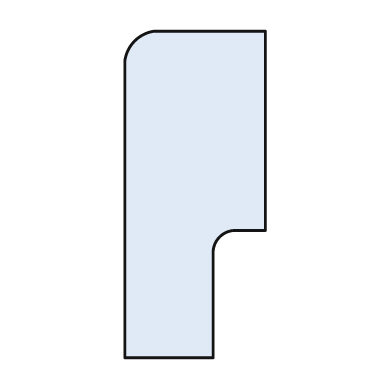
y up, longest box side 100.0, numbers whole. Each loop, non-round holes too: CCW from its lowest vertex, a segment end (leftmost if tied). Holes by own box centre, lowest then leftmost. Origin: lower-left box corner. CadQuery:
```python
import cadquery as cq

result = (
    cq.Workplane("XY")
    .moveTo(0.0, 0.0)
    .lineTo(27.0, 0.0)
    .lineTo(27.0, 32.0)
    .threePointArc((29.0, 37.0), (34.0, 39.0))
    .lineTo(43.0, 39.0)
    .lineTo(43.0, 100.0)
    .lineTo(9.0, 100.0)
    .threePointArc((3.0, 97.0), (0.0, 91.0))
    .close()
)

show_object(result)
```